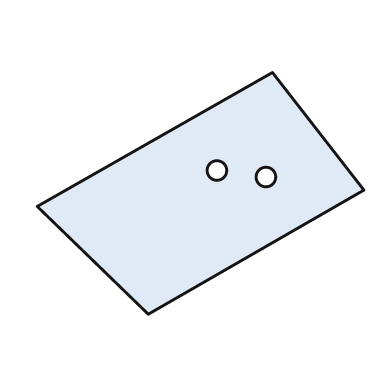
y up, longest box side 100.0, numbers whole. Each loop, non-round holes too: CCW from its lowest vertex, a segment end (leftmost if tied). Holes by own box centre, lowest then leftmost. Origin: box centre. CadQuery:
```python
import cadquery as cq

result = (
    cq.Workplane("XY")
    .moveTo(-16.0, -37.0)
    .lineTo(50.0, 1.0)
    .lineTo(22.0, 37.0)
    .lineTo(-50.0, -4.0)
    .close()
    .moveTo(20.0, 5.0)
    .circle(3.0)
    .moveTo(5.0, 7.0)
    .circle(3.0)
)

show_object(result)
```